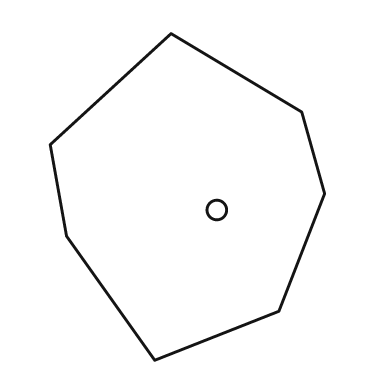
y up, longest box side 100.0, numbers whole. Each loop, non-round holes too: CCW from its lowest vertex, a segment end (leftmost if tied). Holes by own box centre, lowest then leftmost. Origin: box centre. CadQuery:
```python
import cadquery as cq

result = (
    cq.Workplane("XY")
    .moveTo(-10.0, -50.0)
    .lineTo(28.0, -35.0)
    .lineTo(42.0, 1.0)
    .lineTo(35.0, 26.0)
    .lineTo(-5.0, 50.0)
    .lineTo(-42.0, 16.0)
    .lineTo(-37.0, -12.0)
    .close()
    .moveTo(9.0, -4.0)
    .circle(3.0)
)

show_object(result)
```